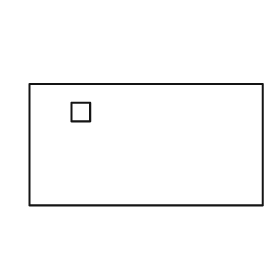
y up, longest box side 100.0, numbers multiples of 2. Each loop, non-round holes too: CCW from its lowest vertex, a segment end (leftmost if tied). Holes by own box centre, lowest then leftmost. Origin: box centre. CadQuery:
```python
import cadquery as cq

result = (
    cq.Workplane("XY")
    .moveTo(-50.0, -26.0)
    .lineTo(50.0, -26.0)
    .lineTo(50.0, 26.0)
    .lineTo(-50.0, 26.0)
    .close()
    .moveTo(-32.0, 10.0)
    .lineTo(-24.0, 10.0)
    .lineTo(-24.0, 18.0)
    .lineTo(-32.0, 18.0)
    .close()
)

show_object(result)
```